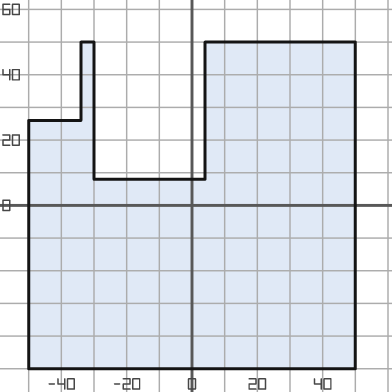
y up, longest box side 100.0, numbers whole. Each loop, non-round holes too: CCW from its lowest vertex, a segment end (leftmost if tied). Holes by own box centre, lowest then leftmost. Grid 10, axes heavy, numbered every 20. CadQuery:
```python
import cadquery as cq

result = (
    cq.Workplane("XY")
    .moveTo(-50.0, -50.0)
    .lineTo(50.0, -50.0)
    .lineTo(50.0, 50.0)
    .lineTo(4.0, 50.0)
    .lineTo(4.0, 8.0)
    .lineTo(-30.0, 8.0)
    .lineTo(-30.0, 50.0)
    .lineTo(-34.0, 50.0)
    .lineTo(-34.0, 26.0)
    .lineTo(-50.0, 26.0)
    .close()
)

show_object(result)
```